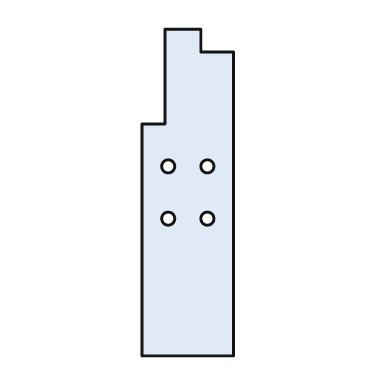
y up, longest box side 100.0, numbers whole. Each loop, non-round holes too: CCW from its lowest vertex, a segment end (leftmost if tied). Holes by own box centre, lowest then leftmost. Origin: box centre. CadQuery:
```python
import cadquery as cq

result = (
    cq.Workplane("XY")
    .moveTo(-14.0, -50.0)
    .lineTo(14.0, -50.0)
    .lineTo(14.0, 43.0)
    .lineTo(4.0, 43.0)
    .lineTo(4.0, 50.0)
    .lineTo(-7.0, 50.0)
    .lineTo(-7.0, 21.0)
    .lineTo(-14.0, 21.0)
    .close()
    .moveTo(-6.0, -8.0)
    .circle(2.0)
    .moveTo(6.0, -8.0)
    .circle(2.0)
    .moveTo(-6.0, 8.0)
    .circle(2.0)
    .moveTo(6.0, 8.0)
    .circle(2.0)
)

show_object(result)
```